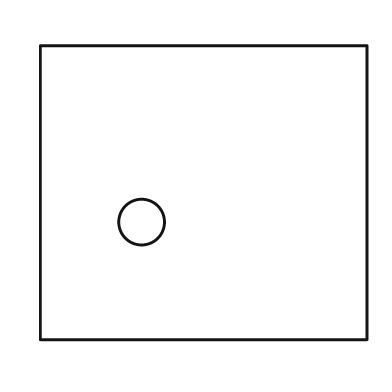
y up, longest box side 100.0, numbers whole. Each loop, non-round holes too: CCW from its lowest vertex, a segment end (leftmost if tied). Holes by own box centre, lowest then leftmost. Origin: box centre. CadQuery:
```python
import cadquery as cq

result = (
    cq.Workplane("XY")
    .moveTo(-50.0, -45.0)
    .lineTo(50.0, -45.0)
    .lineTo(50.0, 45.0)
    .lineTo(-50.0, 45.0)
    .close()
    .moveTo(-19.0, -9.0)
    .circle(7.0)
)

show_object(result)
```